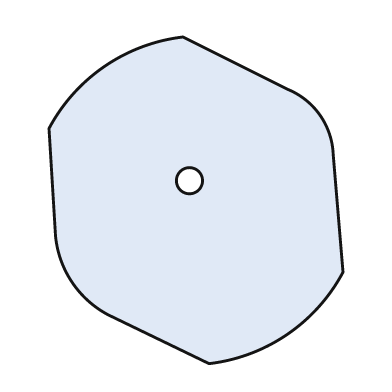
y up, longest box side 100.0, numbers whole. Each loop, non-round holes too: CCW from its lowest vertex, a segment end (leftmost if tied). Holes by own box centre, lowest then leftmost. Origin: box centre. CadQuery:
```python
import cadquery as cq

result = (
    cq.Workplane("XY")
    .moveTo(4.0, -50.0)
    .threePointArc((28.0, -41.0), (45.0, -22.0))
    .lineTo(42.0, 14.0)
    .threePointArc((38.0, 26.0), (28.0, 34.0))
    .lineTo(-4.0, 50.0)
    .threePointArc((-28.0, 41.0), (-45.0, 22.0))
    .lineTo(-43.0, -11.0)
    .threePointArc((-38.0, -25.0), (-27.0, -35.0))
    .close()
    .moveTo(-2.0, 6.0)
    .circle(4.0)
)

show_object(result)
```